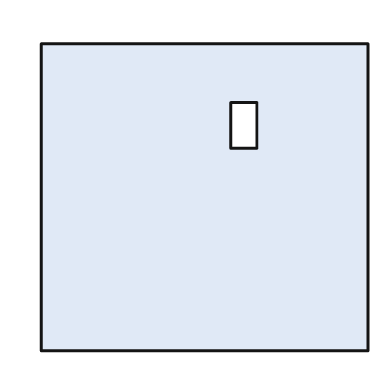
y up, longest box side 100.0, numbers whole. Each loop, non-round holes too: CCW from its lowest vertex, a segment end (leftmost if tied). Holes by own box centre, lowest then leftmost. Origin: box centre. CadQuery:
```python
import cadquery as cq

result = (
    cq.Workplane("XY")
    .moveTo(-50.0, -47.0)
    .lineTo(50.0, -47.0)
    .lineTo(50.0, 47.0)
    .lineTo(-50.0, 47.0)
    .close()
    .moveTo(8.0, 15.0)
    .lineTo(16.0, 15.0)
    .lineTo(16.0, 29.0)
    .lineTo(8.0, 29.0)
    .close()
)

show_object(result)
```